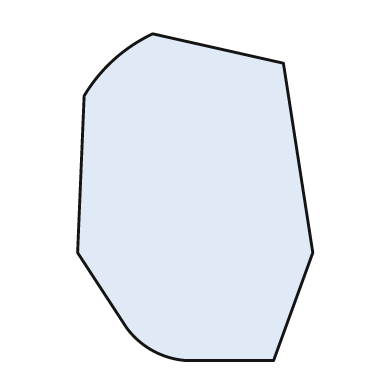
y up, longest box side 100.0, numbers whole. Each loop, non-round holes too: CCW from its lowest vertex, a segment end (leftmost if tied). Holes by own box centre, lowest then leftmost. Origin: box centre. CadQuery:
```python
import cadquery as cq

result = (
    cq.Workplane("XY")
    .moveTo(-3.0, -50.0)
    .lineTo(24.0, -50.0)
    .lineTo(36.0, -17.0)
    .lineTo(27.0, 41.0)
    .lineTo(-13.0, 50.0)
    .threePointArc((-25.0, 42.0), (-34.0, 31.0))
    .lineTo(-36.0, -17.0)
    .lineTo(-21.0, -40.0)
    .threePointArc((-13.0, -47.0), (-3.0, -50.0))
    .close()
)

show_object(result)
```